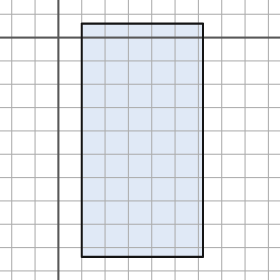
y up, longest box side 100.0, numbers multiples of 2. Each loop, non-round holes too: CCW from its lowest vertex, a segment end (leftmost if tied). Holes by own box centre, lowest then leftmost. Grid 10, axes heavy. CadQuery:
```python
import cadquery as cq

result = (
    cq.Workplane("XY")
    .moveTo(10.0, -94.0)
    .lineTo(62.0, -94.0)
    .lineTo(62.0, 6.0)
    .lineTo(10.0, 6.0)
    .close()
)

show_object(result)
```